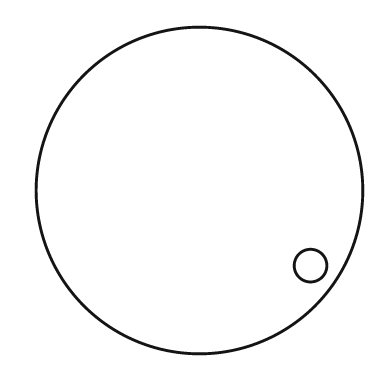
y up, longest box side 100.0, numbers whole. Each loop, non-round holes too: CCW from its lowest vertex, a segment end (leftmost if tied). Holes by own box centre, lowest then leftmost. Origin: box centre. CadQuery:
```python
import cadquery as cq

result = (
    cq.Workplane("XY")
    .moveTo(0.0, 0.0)
    .circle(50.0)
    .moveTo(34.0, -23.0)
    .circle(5.0)
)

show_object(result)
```